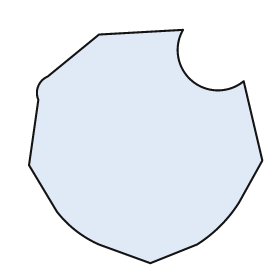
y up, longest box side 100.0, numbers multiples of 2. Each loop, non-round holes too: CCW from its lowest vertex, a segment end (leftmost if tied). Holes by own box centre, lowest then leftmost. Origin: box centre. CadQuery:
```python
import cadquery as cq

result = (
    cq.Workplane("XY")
    .moveTo(2.0, -50.0)
    .lineTo(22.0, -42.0)
    .threePointArc((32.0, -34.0), (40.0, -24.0))
    .lineTo(50.0, -6.0)
    .lineTo(42.0, 28.0)
    .threePointArc((20.0, 28.0), (16.0, 50.0))
    .lineTo(-20.0, 48.0)
    .lineTo(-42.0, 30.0)
    .threePointArc((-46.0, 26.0), (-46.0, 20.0))
    .lineTo(-50.0, -8.0)
    .lineTo(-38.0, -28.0)
    .threePointArc((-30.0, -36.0), (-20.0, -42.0))
    .close()
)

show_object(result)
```